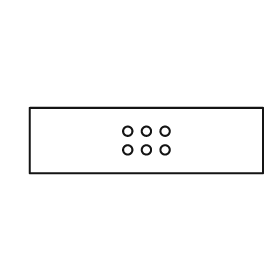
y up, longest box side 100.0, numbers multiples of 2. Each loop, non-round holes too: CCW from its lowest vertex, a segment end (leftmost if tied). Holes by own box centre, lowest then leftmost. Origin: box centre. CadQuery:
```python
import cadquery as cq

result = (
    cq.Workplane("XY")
    .moveTo(-50.0, -14.0)
    .lineTo(50.0, -14.0)
    .lineTo(50.0, 14.0)
    .lineTo(-50.0, 14.0)
    .close()
    .moveTo(-8.0, -4.0)
    .circle(2.0)
    .moveTo(0.0, -4.0)
    .circle(2.0)
    .moveTo(8.0, -4.0)
    .circle(2.0)
    .moveTo(-8.0, 4.0)
    .circle(2.0)
    .moveTo(0.0, 4.0)
    .circle(2.0)
    .moveTo(8.0, 4.0)
    .circle(2.0)
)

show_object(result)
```